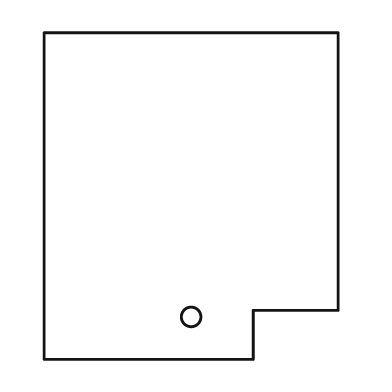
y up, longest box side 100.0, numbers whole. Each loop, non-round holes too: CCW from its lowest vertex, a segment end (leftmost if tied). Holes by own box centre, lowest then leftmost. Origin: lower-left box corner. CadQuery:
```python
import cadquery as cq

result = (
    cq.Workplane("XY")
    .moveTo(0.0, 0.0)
    .lineTo(64.0, 0.0)
    .lineTo(64.0, 15.0)
    .lineTo(90.0, 15.0)
    .lineTo(90.0, 100.0)
    .lineTo(0.0, 100.0)
    .close()
    .moveTo(45.0, 13.0)
    .circle(3.0)
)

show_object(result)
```